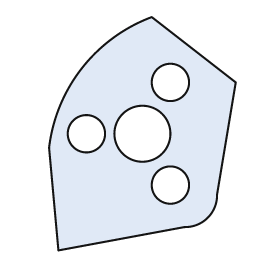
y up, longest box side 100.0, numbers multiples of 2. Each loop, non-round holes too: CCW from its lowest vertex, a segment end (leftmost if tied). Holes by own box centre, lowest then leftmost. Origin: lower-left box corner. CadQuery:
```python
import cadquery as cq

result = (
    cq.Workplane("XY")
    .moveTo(4.0, 0.0)
    .lineTo(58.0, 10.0)
    .threePointArc((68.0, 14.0), (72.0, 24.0))
    .lineTo(80.0, 72.0)
    .lineTo(44.0, 100.0)
    .threePointArc((14.0, 78.0), (0.0, 44.0))
    .close()
    .moveTo(52.0, 28.0)
    .circle(8.0)
    .moveTo(16.0, 50.0)
    .circle(8.0)
    .moveTo(40.0, 50.0)
    .circle(12.0)
    .moveTo(52.0, 72.0)
    .circle(8.0)
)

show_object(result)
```